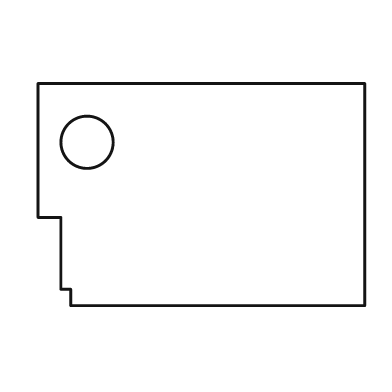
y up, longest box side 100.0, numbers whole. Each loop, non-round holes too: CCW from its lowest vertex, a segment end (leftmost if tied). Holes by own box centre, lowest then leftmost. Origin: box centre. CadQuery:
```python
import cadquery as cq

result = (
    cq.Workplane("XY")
    .moveTo(-40.0, -34.0)
    .lineTo(50.0, -34.0)
    .lineTo(50.0, 34.0)
    .lineTo(-50.0, 34.0)
    .lineTo(-50.0, -7.0)
    .lineTo(-43.0, -7.0)
    .lineTo(-43.0, -29.0)
    .lineTo(-40.0, -29.0)
    .close()
    .moveTo(-35.0, 16.0)
    .circle(8.0)
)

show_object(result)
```